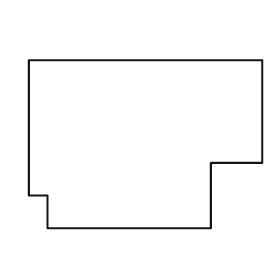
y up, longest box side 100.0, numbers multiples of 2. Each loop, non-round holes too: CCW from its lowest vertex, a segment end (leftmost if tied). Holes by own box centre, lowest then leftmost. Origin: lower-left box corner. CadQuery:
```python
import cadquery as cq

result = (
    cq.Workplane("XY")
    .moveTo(8.0, 0.0)
    .lineTo(78.0, 0.0)
    .lineTo(78.0, 28.0)
    .lineTo(100.0, 28.0)
    .lineTo(100.0, 72.0)
    .lineTo(0.0, 72.0)
    .lineTo(0.0, 14.0)
    .lineTo(8.0, 14.0)
    .close()
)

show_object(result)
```